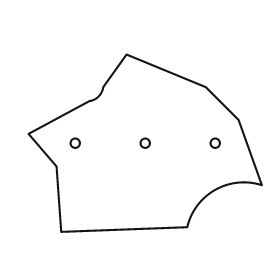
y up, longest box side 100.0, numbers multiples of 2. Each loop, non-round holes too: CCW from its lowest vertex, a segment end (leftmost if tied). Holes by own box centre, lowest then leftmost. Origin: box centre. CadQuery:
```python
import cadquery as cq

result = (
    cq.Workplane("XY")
    .moveTo(-36.0, -38.0)
    .lineTo(18.0, -36.0)
    .threePointArc((30.0, -20.0), (50.0, -18.0))
    .lineTo(40.0, 10.0)
    .lineTo(26.0, 24.0)
    .lineTo(-8.0, 38.0)
    .lineTo(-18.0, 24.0)
    .threePointArc((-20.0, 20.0), (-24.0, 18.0))
    .lineTo(-50.0, 4.0)
    .lineTo(-38.0, -10.0)
    .close()
    .moveTo(-30.0, 0.0)
    .circle(2.0)
    .moveTo(0.0, 0.0)
    .circle(2.0)
    .moveTo(30.0, 0.0)
    .circle(2.0)
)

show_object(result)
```